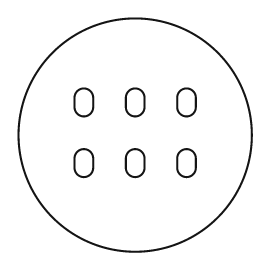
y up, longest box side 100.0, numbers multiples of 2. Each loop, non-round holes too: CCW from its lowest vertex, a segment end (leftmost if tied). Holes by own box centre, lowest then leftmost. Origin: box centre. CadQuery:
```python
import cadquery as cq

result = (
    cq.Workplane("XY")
    .moveTo(0.0, 0.0)
    .circle(50.0)
    .moveTo(-26.0, -14.0)
    .threePointArc((-22.0, -18.0), (-18.0, -14.0))
    .lineTo(-18.0, -10.0)
    .threePointArc((-22.0, -6.0), (-26.0, -10.0))
    .close()
    .moveTo(-4.0, -14.0)
    .threePointArc((0.0, -18.0), (4.0, -14.0))
    .lineTo(4.0, -10.0)
    .threePointArc((0.0, -6.0), (-4.0, -10.0))
    .close()
    .moveTo(18.0, -14.0)
    .threePointArc((22.0, -18.0), (26.0, -14.0))
    .lineTo(26.0, -10.0)
    .threePointArc((22.0, -6.0), (18.0, -10.0))
    .close()
    .moveTo(-26.0, 12.0)
    .threePointArc((-22.0, 8.0), (-18.0, 12.0))
    .lineTo(-18.0, 16.0)
    .threePointArc((-22.0, 20.0), (-26.0, 16.0))
    .close()
    .moveTo(-4.0, 12.0)
    .threePointArc((0.0, 8.0), (4.0, 12.0))
    .lineTo(4.0, 16.0)
    .threePointArc((0.0, 20.0), (-4.0, 16.0))
    .close()
    .moveTo(18.0, 12.0)
    .threePointArc((22.0, 8.0), (26.0, 12.0))
    .lineTo(26.0, 16.0)
    .threePointArc((22.0, 20.0), (18.0, 16.0))
    .close()
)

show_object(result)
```